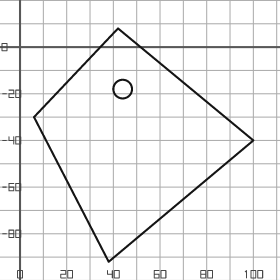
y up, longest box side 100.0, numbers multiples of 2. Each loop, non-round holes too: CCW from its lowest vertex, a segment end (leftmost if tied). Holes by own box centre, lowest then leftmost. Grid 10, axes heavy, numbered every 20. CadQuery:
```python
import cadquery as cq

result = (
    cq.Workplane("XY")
    .moveTo(38.0, -92.0)
    .lineTo(100.0, -40.0)
    .lineTo(42.0, 8.0)
    .lineTo(6.0, -30.0)
    .close()
    .moveTo(44.0, -18.0)
    .circle(4.0)
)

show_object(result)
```